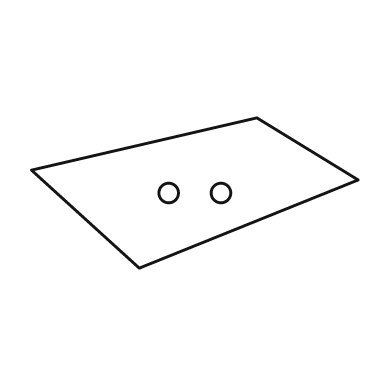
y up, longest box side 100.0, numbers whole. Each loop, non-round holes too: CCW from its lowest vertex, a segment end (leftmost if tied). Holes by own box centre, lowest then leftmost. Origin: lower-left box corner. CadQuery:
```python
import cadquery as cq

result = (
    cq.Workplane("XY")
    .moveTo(33.0, 0.0)
    .lineTo(100.0, 27.0)
    .lineTo(69.0, 46.0)
    .lineTo(0.0, 30.0)
    .close()
    .moveTo(42.0, 23.0)
    .circle(3.0)
    .moveTo(58.0, 23.0)
    .circle(3.0)
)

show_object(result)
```